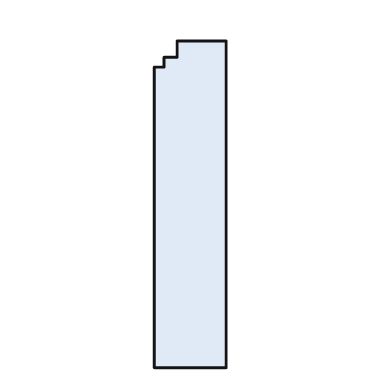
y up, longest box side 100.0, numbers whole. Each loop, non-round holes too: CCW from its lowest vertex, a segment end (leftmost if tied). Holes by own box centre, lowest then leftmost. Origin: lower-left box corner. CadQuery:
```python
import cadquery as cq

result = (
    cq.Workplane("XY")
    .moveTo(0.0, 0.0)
    .lineTo(22.0, 0.0)
    .lineTo(22.0, 100.0)
    .lineTo(7.0, 100.0)
    .lineTo(7.0, 95.0)
    .lineTo(3.0, 95.0)
    .lineTo(3.0, 92.0)
    .lineTo(0.0, 92.0)
    .close()
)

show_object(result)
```